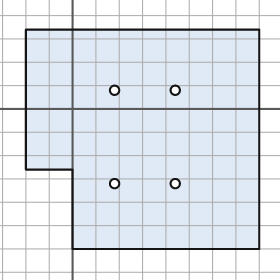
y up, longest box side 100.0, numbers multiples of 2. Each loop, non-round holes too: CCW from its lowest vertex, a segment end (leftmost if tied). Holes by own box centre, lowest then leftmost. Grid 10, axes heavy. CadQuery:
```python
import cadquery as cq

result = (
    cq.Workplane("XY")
    .moveTo(0.0, -60.0)
    .lineTo(80.0, -60.0)
    .lineTo(80.0, 34.0)
    .lineTo(-20.0, 34.0)
    .lineTo(-20.0, -26.0)
    .lineTo(0.0, -26.0)
    .close()
    .moveTo(18.0, -32.0)
    .circle(2.0)
    .moveTo(44.0, -32.0)
    .circle(2.0)
    .moveTo(18.0, 8.0)
    .circle(2.0)
    .moveTo(44.0, 8.0)
    .circle(2.0)
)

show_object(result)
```